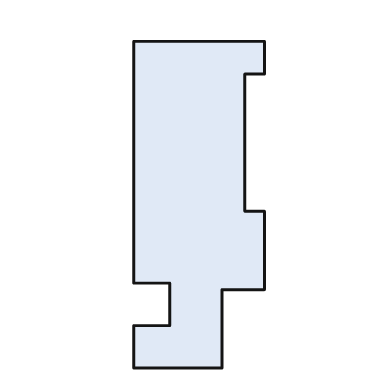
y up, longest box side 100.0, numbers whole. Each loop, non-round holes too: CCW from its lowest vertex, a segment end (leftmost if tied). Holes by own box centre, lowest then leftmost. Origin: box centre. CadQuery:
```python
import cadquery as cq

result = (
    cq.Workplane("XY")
    .moveTo(-20.0, -50.0)
    .lineTo(7.0, -50.0)
    .lineTo(7.0, -26.0)
    .lineTo(20.0, -26.0)
    .lineTo(20.0, -2.0)
    .lineTo(14.0, -2.0)
    .lineTo(14.0, 40.0)
    .lineTo(20.0, 40.0)
    .lineTo(20.0, 50.0)
    .lineTo(-20.0, 50.0)
    .lineTo(-20.0, -24.0)
    .lineTo(-9.0, -24.0)
    .lineTo(-9.0, -37.0)
    .lineTo(-20.0, -37.0)
    .close()
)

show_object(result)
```